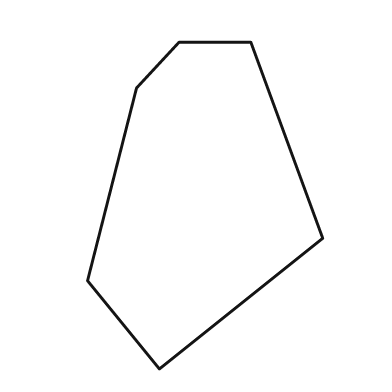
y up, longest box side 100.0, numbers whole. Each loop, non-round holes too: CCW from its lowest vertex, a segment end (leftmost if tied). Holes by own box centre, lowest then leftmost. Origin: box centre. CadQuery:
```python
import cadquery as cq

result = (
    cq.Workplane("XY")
    .moveTo(-14.0, -50.0)
    .lineTo(36.0, -10.0)
    .lineTo(14.0, 50.0)
    .lineTo(-8.0, 50.0)
    .lineTo(-21.0, 36.0)
    .lineTo(-36.0, -23.0)
    .close()
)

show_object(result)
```